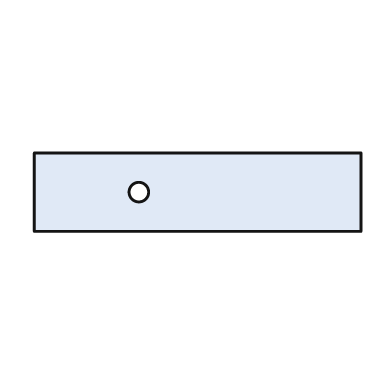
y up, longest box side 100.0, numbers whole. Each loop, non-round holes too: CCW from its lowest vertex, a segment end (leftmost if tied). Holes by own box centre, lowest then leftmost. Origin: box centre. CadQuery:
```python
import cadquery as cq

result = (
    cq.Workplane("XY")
    .moveTo(-50.0, -12.0)
    .lineTo(50.0, -12.0)
    .lineTo(50.0, 12.0)
    .lineTo(-50.0, 12.0)
    .close()
    .moveTo(-18.0, 0.0)
    .circle(3.0)
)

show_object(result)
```